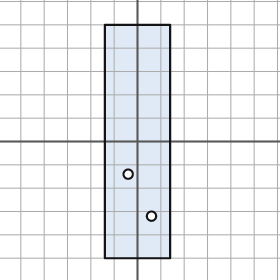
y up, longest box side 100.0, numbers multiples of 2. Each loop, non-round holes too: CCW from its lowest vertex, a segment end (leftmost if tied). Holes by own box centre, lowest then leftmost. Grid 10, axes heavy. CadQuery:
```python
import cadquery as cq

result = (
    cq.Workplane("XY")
    .moveTo(-14.0, -50.0)
    .lineTo(14.0, -50.0)
    .lineTo(14.0, 50.0)
    .lineTo(-14.0, 50.0)
    .close()
    .moveTo(6.0, -32.0)
    .circle(2.0)
    .moveTo(-4.0, -14.0)
    .circle(2.0)
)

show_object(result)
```